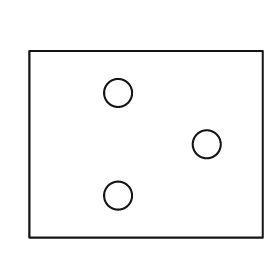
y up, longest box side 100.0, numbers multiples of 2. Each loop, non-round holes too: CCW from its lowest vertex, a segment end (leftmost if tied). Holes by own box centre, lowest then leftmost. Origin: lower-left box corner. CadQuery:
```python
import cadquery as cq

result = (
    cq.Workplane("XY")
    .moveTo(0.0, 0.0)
    .lineTo(100.0, 0.0)
    .lineTo(100.0, 80.0)
    .lineTo(0.0, 80.0)
    .close()
    .moveTo(38.0, 18.0)
    .circle(6.0)
    .moveTo(76.0, 40.0)
    .circle(6.0)
    .moveTo(38.0, 62.0)
    .circle(6.0)
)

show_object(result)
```